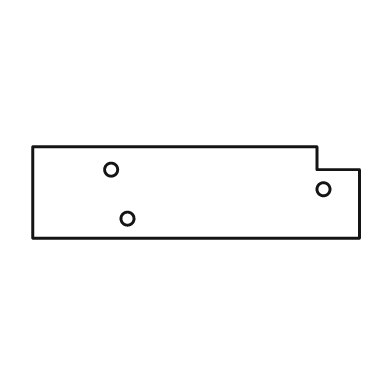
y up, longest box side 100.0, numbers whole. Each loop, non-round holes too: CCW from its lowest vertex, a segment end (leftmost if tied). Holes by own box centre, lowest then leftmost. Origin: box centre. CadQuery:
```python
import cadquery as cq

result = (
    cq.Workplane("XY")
    .moveTo(-50.0, -14.0)
    .lineTo(50.0, -14.0)
    .lineTo(50.0, 7.0)
    .lineTo(37.0, 7.0)
    .lineTo(37.0, 14.0)
    .lineTo(-50.0, 14.0)
    .close()
    .moveTo(-21.0, -8.0)
    .circle(2.0)
    .moveTo(39.0, 1.0)
    .circle(2.0)
    .moveTo(-26.0, 7.0)
    .circle(2.0)
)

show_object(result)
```